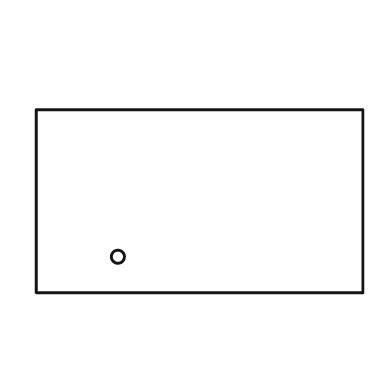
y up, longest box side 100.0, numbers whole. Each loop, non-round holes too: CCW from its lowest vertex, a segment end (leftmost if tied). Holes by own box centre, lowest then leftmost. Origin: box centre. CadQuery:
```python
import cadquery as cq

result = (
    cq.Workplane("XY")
    .moveTo(-50.0, -28.0)
    .lineTo(50.0, -28.0)
    .lineTo(50.0, 28.0)
    .lineTo(-50.0, 28.0)
    .close()
    .moveTo(-25.0, -17.0)
    .circle(2.0)
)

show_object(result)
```